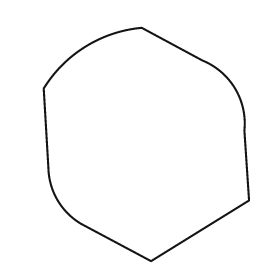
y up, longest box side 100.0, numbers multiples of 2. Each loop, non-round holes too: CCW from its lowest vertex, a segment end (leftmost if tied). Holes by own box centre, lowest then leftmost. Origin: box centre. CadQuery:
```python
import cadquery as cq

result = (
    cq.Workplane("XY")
    .moveTo(2.0, -50.0)
    .lineTo(44.0, -24.0)
    .lineTo(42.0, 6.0)
    .threePointArc((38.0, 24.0), (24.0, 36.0))
    .lineTo(-2.0, 50.0)
    .threePointArc((-26.0, 42.0), (-44.0, 24.0))
    .lineTo(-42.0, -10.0)
    .threePointArc((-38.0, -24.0), (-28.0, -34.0))
    .close()
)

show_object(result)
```